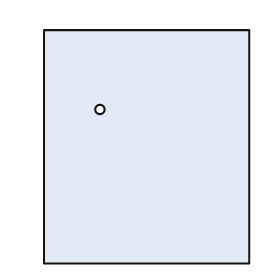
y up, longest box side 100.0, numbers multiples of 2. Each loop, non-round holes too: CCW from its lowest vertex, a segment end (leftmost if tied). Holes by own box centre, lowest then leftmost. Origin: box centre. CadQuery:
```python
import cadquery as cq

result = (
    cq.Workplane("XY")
    .moveTo(-44.0, -50.0)
    .lineTo(44.0, -50.0)
    .lineTo(44.0, 50.0)
    .lineTo(-44.0, 50.0)
    .close()
    .moveTo(-20.0, 16.0)
    .circle(2.0)
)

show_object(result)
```